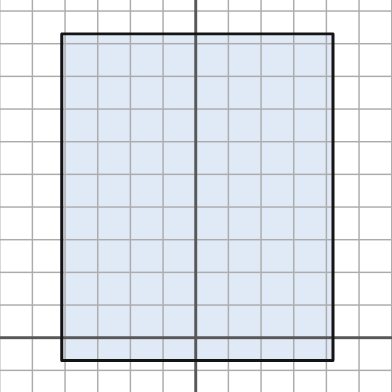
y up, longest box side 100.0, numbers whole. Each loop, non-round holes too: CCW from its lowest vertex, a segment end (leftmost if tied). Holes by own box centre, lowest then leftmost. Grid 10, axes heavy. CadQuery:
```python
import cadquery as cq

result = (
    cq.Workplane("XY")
    .moveTo(-41.0, -7.0)
    .lineTo(42.0, -7.0)
    .lineTo(42.0, 93.0)
    .lineTo(-41.0, 93.0)
    .close()
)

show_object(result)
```